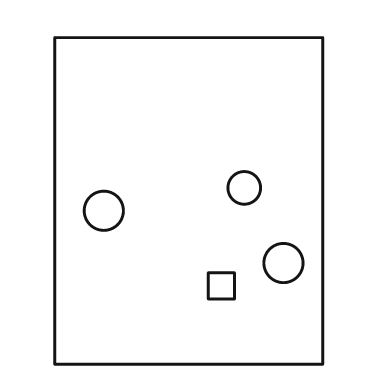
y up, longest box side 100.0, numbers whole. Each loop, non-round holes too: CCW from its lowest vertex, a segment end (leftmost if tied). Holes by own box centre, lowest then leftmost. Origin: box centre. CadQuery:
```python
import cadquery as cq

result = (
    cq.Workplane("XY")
    .moveTo(-41.0, -50.0)
    .lineTo(41.0, -50.0)
    .lineTo(41.0, 50.0)
    .lineTo(-41.0, 50.0)
    .close()
    .moveTo(6.0, -30.0)
    .lineTo(14.0, -30.0)
    .lineTo(14.0, -22.0)
    .lineTo(6.0, -22.0)
    .close()
    .moveTo(29.0, -19.0)
    .circle(6.0)
    .moveTo(-26.0, -3.0)
    .circle(6.0)
    .moveTo(17.0, 4.0)
    .circle(5.0)
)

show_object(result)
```